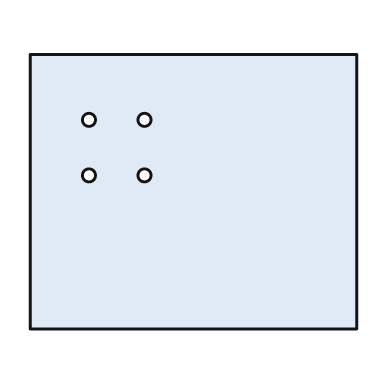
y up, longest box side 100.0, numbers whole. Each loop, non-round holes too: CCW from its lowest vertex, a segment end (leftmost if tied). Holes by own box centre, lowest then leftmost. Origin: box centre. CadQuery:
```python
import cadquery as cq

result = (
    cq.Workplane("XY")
    .moveTo(-50.0, -42.0)
    .lineTo(50.0, -42.0)
    .lineTo(50.0, 42.0)
    .lineTo(-50.0, 42.0)
    .close()
    .moveTo(-32.0, 5.0)
    .circle(2.0)
    .moveTo(-15.0, 5.0)
    .circle(2.0)
    .moveTo(-32.0, 22.0)
    .circle(2.0)
    .moveTo(-15.0, 22.0)
    .circle(2.0)
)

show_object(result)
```